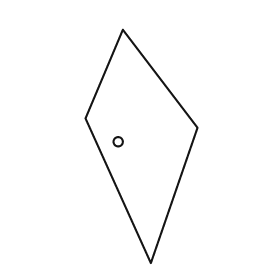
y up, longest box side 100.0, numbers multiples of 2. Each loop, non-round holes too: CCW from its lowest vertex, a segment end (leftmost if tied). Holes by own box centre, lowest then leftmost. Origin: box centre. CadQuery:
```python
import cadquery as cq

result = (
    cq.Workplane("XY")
    .moveTo(4.0, -50.0)
    .lineTo(24.0, 8.0)
    .lineTo(-8.0, 50.0)
    .lineTo(-24.0, 12.0)
    .close()
    .moveTo(-10.0, 2.0)
    .circle(2.0)
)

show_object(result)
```